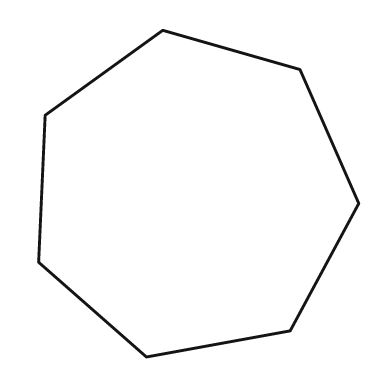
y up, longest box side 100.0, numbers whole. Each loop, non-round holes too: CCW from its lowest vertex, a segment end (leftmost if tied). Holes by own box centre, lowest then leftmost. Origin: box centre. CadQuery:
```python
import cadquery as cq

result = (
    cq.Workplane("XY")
    .moveTo(-16.0, -50.0)
    .lineTo(28.0, -42.0)
    .lineTo(49.0, -3.0)
    .lineTo(31.0, 38.0)
    .lineTo(-11.0, 50.0)
    .lineTo(-47.0, 24.0)
    .lineTo(-49.0, -21.0)
    .close()
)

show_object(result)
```